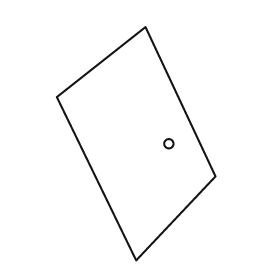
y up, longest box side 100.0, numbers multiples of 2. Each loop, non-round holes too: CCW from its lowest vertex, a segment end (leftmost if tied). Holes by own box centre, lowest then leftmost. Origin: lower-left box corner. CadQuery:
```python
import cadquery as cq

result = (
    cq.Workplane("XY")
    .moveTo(34.0, 0.0)
    .lineTo(68.0, 36.0)
    .lineTo(38.0, 100.0)
    .lineTo(0.0, 70.0)
    .close()
    .moveTo(48.0, 50.0)
    .circle(2.0)
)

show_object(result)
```